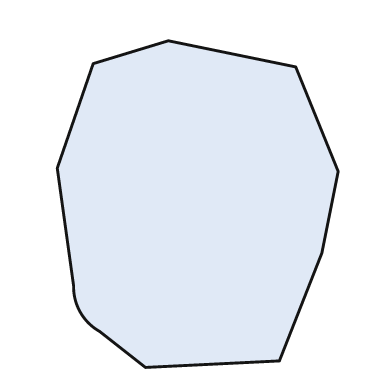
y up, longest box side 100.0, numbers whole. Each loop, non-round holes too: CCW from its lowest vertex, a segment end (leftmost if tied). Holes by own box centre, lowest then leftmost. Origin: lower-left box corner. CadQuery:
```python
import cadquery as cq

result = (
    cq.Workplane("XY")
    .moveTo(27.0, 0.0)
    .lineTo(68.0, 2.0)
    .lineTo(81.0, 35.0)
    .lineTo(86.0, 60.0)
    .lineTo(73.0, 92.0)
    .lineTo(34.0, 100.0)
    .lineTo(11.0, 93.0)
    .lineTo(0.0, 61.0)
    .lineTo(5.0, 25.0)
    .threePointArc((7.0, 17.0), (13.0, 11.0))
    .close()
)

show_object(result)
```